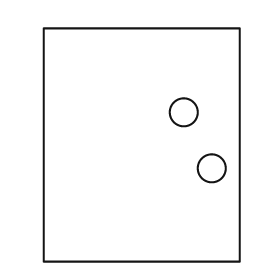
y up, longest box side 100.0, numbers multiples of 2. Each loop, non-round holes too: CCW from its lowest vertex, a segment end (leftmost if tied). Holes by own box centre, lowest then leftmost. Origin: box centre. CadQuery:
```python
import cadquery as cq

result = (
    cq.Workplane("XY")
    .moveTo(-42.0, -50.0)
    .lineTo(42.0, -50.0)
    .lineTo(42.0, 50.0)
    .lineTo(-42.0, 50.0)
    .close()
    .moveTo(30.0, -10.0)
    .circle(6.0)
    .moveTo(18.0, 14.0)
    .circle(6.0)
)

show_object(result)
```